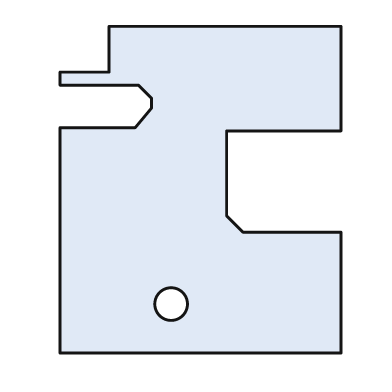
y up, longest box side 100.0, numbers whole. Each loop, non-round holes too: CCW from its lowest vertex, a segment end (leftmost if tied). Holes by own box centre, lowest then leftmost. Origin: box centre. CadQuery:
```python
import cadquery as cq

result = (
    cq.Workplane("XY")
    .moveTo(-43.0, -50.0)
    .lineTo(43.0, -50.0)
    .lineTo(43.0, -13.0)
    .lineTo(13.0, -13.0)
    .lineTo(8.0, -8.0)
    .lineTo(8.0, 18.0)
    .lineTo(43.0, 18.0)
    .lineTo(43.0, 50.0)
    .lineTo(-28.0, 50.0)
    .lineTo(-28.0, 36.0)
    .lineTo(-43.0, 36.0)
    .lineTo(-43.0, 32.0)
    .lineTo(-19.0, 32.0)
    .lineTo(-15.0, 28.0)
    .lineTo(-15.0, 25.0)
    .lineTo(-20.0, 19.0)
    .lineTo(-43.0, 19.0)
    .close()
    .moveTo(-9.0, -35.0)
    .circle(5.0)
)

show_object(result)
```